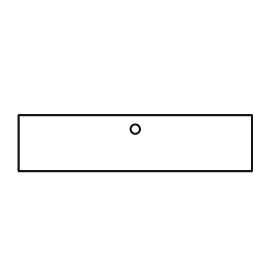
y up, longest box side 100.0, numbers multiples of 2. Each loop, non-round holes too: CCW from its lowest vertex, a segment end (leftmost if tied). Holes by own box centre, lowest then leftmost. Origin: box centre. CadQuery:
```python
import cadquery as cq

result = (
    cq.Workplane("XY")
    .moveTo(-50.0, -12.0)
    .lineTo(50.0, -12.0)
    .lineTo(50.0, 12.0)
    .lineTo(-50.0, 12.0)
    .close()
    .moveTo(0.0, 6.0)
    .circle(2.0)
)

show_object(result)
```